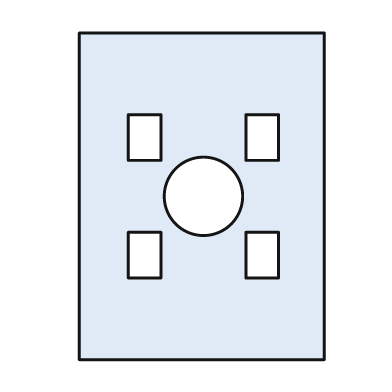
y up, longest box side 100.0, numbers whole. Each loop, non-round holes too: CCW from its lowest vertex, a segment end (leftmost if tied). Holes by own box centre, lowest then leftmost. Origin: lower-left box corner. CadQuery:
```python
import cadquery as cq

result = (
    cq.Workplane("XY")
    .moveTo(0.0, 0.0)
    .lineTo(75.0, 0.0)
    .lineTo(75.0, 100.0)
    .lineTo(0.0, 100.0)
    .close()
    .moveTo(15.0, 25.0)
    .lineTo(25.0, 25.0)
    .lineTo(25.0, 39.0)
    .lineTo(15.0, 39.0)
    .close()
    .moveTo(51.0, 25.0)
    .lineTo(61.0, 25.0)
    .lineTo(61.0, 39.0)
    .lineTo(51.0, 39.0)
    .close()
    .moveTo(38.0, 50.0)
    .circle(12.0)
    .moveTo(15.0, 61.0)
    .lineTo(25.0, 61.0)
    .lineTo(25.0, 75.0)
    .lineTo(15.0, 75.0)
    .close()
    .moveTo(51.0, 61.0)
    .lineTo(61.0, 61.0)
    .lineTo(61.0, 75.0)
    .lineTo(51.0, 75.0)
    .close()
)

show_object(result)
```